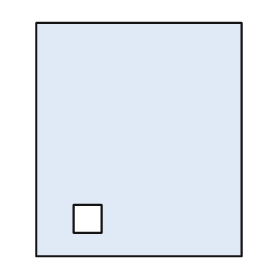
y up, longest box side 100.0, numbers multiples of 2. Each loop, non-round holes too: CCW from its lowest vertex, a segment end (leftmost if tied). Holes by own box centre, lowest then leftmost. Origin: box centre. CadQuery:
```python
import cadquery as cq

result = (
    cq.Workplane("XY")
    .moveTo(-44.0, -50.0)
    .lineTo(44.0, -50.0)
    .lineTo(44.0, 50.0)
    .lineTo(-44.0, 50.0)
    .close()
    .moveTo(-28.0, -40.0)
    .lineTo(-16.0, -40.0)
    .lineTo(-16.0, -28.0)
    .lineTo(-28.0, -28.0)
    .close()
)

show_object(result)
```